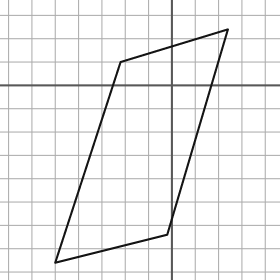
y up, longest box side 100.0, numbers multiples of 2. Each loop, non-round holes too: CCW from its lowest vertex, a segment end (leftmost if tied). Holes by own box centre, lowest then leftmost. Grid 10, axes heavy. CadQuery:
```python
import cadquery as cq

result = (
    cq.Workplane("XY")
    .moveTo(-50.0, -76.0)
    .lineTo(-2.0, -64.0)
    .lineTo(24.0, 24.0)
    .lineTo(-22.0, 10.0)
    .close()
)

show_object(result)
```